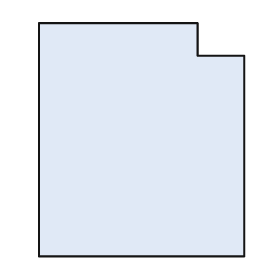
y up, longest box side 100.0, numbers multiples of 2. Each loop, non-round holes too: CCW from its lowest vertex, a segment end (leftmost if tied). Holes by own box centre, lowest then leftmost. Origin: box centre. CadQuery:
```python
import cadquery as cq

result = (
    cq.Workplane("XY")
    .moveTo(-44.0, -50.0)
    .lineTo(44.0, -50.0)
    .lineTo(44.0, 36.0)
    .lineTo(24.0, 36.0)
    .lineTo(24.0, 50.0)
    .lineTo(-44.0, 50.0)
    .close()
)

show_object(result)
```